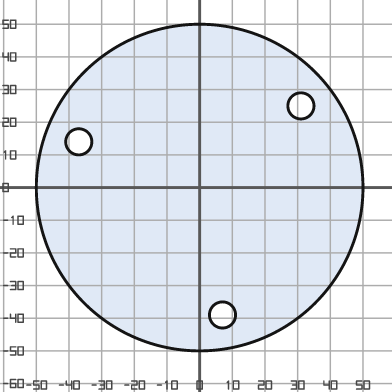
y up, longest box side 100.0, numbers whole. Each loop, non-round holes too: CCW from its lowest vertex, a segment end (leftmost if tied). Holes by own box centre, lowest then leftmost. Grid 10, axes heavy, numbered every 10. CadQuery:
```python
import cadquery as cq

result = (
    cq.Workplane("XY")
    .moveTo(0.0, 0.0)
    .circle(50.0)
    .moveTo(7.0, -39.0)
    .circle(4.0)
    .moveTo(-37.0, 14.0)
    .circle(4.0)
    .moveTo(31.0, 25.0)
    .circle(4.0)
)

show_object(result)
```